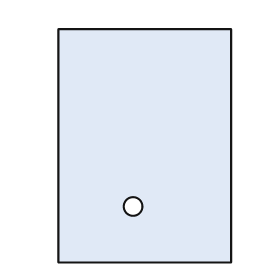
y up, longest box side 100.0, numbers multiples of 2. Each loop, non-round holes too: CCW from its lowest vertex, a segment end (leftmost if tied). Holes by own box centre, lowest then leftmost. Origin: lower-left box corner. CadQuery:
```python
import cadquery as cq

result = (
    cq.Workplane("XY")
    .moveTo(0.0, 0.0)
    .lineTo(74.0, 0.0)
    .lineTo(74.0, 100.0)
    .lineTo(0.0, 100.0)
    .close()
    .moveTo(32.0, 24.0)
    .circle(4.0)
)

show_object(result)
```